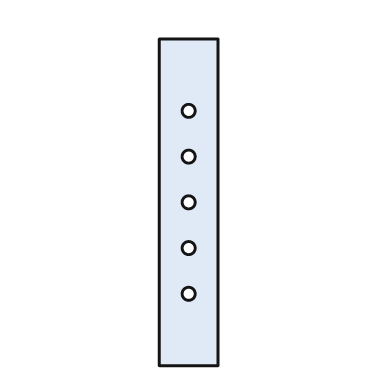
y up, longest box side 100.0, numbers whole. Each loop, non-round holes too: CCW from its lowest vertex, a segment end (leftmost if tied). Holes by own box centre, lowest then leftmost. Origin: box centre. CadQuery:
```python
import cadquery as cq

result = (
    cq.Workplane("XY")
    .moveTo(-9.0, -50.0)
    .lineTo(9.0, -50.0)
    .lineTo(9.0, 50.0)
    .lineTo(-9.0, 50.0)
    .close()
    .moveTo(0.0, -28.0)
    .circle(2.0)
    .moveTo(0.0, -14.0)
    .circle(2.0)
    .moveTo(0.0, 0.0)
    .circle(2.0)
    .moveTo(0.0, 14.0)
    .circle(2.0)
    .moveTo(0.0, 28.0)
    .circle(2.0)
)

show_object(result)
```